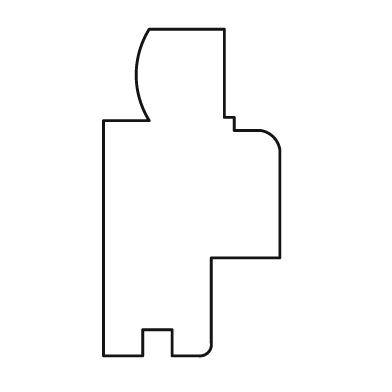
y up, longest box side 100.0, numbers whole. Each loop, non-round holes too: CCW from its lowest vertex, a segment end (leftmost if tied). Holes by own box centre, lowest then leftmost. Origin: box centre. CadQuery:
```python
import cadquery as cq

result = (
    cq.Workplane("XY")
    .moveTo(-27.0, -50.0)
    .lineTo(-15.0, -50.0)
    .lineTo(-15.0, -42.0)
    .lineTo(-6.0, -42.0)
    .lineTo(-6.0, -50.0)
    .lineTo(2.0, -50.0)
    .threePointArc((5.0, -49.0), (6.0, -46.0))
    .lineTo(6.0, -20.0)
    .lineTo(27.0, -20.0)
    .lineTo(27.0, 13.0)
    .threePointArc((25.0, 17.0), (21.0, 19.0))
    .lineTo(13.0, 19.0)
    .lineTo(13.0, 23.0)
    .lineTo(10.0, 23.0)
    .lineTo(10.0, 50.0)
    .lineTo(-13.0, 50.0)
    .threePointArc((-17.0, 36.0), (-13.0, 22.0))
    .lineTo(-27.0, 22.0)
    .close()
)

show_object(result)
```